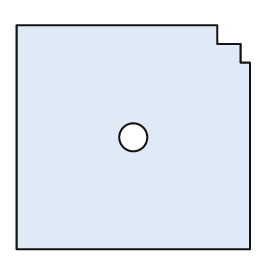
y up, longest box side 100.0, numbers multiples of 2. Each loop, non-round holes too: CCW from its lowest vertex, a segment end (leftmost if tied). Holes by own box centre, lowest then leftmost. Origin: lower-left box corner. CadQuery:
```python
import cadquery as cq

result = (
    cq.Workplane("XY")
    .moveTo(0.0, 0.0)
    .lineTo(100.0, 0.0)
    .lineTo(100.0, 80.0)
    .lineTo(96.0, 80.0)
    .lineTo(96.0, 88.0)
    .lineTo(86.0, 88.0)
    .lineTo(86.0, 96.0)
    .lineTo(0.0, 96.0)
    .close()
    .moveTo(50.0, 48.0)
    .circle(6.0)
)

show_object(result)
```